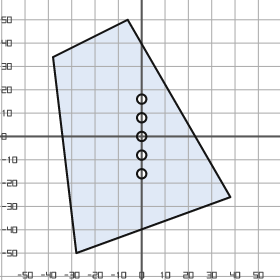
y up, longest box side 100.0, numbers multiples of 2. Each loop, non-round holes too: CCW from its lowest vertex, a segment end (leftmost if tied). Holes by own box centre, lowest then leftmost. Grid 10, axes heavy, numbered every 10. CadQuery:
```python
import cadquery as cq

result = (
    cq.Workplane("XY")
    .moveTo(-28.0, -50.0)
    .lineTo(38.0, -26.0)
    .lineTo(-6.0, 50.0)
    .lineTo(-38.0, 34.0)
    .close()
    .moveTo(0.0, -16.0)
    .circle(2.0)
    .moveTo(0.0, -8.0)
    .circle(2.0)
    .moveTo(0.0, 0.0)
    .circle(2.0)
    .moveTo(0.0, 8.0)
    .circle(2.0)
    .moveTo(0.0, 16.0)
    .circle(2.0)
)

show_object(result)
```